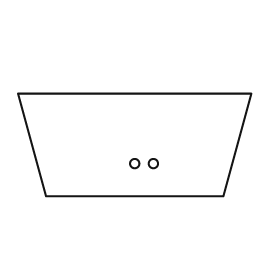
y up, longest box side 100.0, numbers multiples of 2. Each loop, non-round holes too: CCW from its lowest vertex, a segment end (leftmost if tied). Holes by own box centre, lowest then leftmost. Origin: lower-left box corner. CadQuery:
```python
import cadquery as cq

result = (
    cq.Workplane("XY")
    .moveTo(12.0, 0.0)
    .lineTo(88.0, 0.0)
    .lineTo(100.0, 44.0)
    .lineTo(0.0, 44.0)
    .close()
    .moveTo(50.0, 14.0)
    .circle(2.0)
    .moveTo(58.0, 14.0)
    .circle(2.0)
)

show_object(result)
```